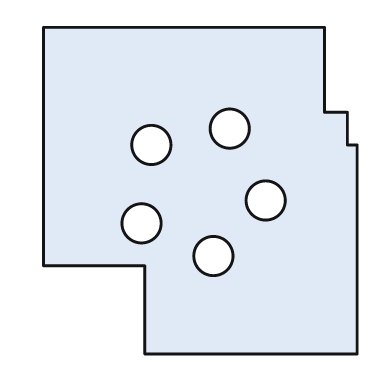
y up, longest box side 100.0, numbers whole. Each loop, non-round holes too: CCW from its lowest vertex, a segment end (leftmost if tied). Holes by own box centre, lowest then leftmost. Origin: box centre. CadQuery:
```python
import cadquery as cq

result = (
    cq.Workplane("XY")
    .moveTo(-17.0, -50.0)
    .lineTo(48.0, -50.0)
    .lineTo(48.0, 14.0)
    .lineTo(45.0, 14.0)
    .lineTo(45.0, 24.0)
    .lineTo(38.0, 24.0)
    .lineTo(38.0, 50.0)
    .lineTo(-48.0, 50.0)
    .lineTo(-48.0, -23.0)
    .lineTo(-17.0, -23.0)
    .close()
    .moveTo(4.0, -20.0)
    .circle(6.0)
    .moveTo(-18.0, -10.0)
    .circle(6.0)
    .moveTo(20.0, -3.0)
    .circle(6.0)
    .moveTo(-15.0, 14.0)
    .circle(6.0)
    .moveTo(9.0, 19.0)
    .circle(6.0)
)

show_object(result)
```